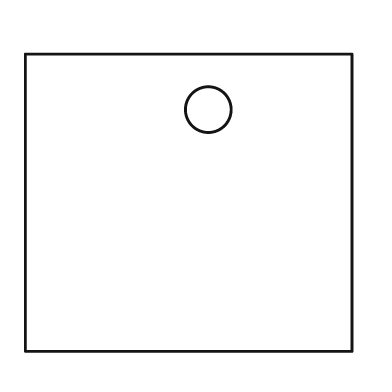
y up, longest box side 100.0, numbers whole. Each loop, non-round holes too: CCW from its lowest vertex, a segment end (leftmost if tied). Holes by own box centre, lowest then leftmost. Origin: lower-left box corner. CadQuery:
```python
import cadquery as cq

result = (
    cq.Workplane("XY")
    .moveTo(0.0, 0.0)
    .lineTo(100.0, 0.0)
    .lineTo(100.0, 91.0)
    .lineTo(0.0, 91.0)
    .close()
    .moveTo(56.0, 74.0)
    .circle(7.0)
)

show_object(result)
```